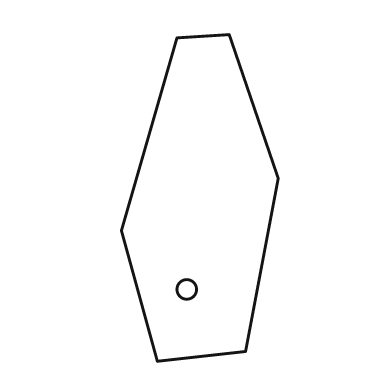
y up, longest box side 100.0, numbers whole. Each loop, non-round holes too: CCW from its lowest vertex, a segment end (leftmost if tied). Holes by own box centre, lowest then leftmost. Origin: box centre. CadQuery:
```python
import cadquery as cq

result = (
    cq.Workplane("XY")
    .moveTo(-13.0, -50.0)
    .lineTo(14.0, -47.0)
    .lineTo(24.0, 6.0)
    .lineTo(9.0, 50.0)
    .lineTo(-7.0, 49.0)
    .lineTo(-24.0, -10.0)
    .close()
    .moveTo(-4.0, -28.0)
    .circle(3.0)
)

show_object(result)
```